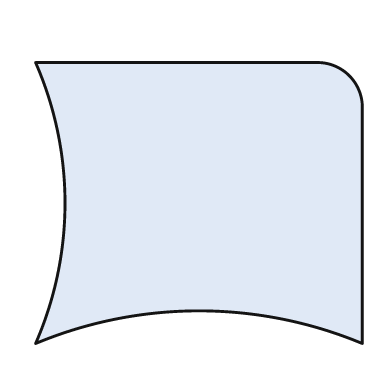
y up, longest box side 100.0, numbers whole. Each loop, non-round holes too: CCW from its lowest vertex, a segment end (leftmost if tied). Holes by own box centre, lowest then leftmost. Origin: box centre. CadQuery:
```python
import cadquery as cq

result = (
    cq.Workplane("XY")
    .moveTo(-50.0, -43.0)
    .threePointArc((0.0, -33.0), (50.0, -43.0))
    .lineTo(50.0, 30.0)
    .threePointArc((46.0, 39.0), (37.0, 43.0))
    .lineTo(-50.0, 43.0)
    .threePointArc((-41.0, 0.0), (-50.0, -43.0))
    .close()
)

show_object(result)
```